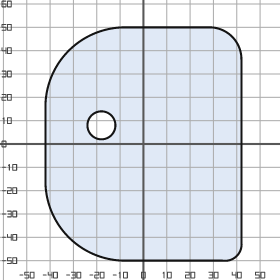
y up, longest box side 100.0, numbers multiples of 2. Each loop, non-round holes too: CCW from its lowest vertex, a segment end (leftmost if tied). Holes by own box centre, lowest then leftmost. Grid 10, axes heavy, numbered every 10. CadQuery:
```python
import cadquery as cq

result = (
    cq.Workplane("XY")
    .moveTo(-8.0, -50.0)
    .lineTo(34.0, -50.0)
    .threePointArc((40.0, -48.0), (42.0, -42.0))
    .lineTo(42.0, 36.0)
    .threePointArc((38.0, 46.0), (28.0, 50.0))
    .lineTo(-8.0, 50.0)
    .threePointArc((-32.0, 40.0), (-42.0, 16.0))
    .lineTo(-42.0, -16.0)
    .threePointArc((-32.0, -40.0), (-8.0, -50.0))
    .close()
    .moveTo(-18.0, 8.0)
    .circle(6.0)
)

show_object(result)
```